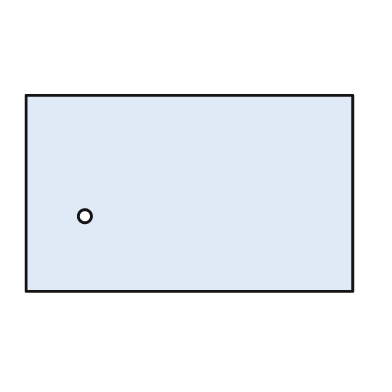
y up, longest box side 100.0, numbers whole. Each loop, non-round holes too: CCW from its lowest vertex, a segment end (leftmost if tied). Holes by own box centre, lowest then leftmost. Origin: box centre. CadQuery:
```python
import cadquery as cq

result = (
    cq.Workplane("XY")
    .moveTo(-50.0, -30.0)
    .lineTo(50.0, -30.0)
    .lineTo(50.0, 30.0)
    .lineTo(-50.0, 30.0)
    .close()
    .moveTo(-32.0, -7.0)
    .circle(2.0)
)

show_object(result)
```